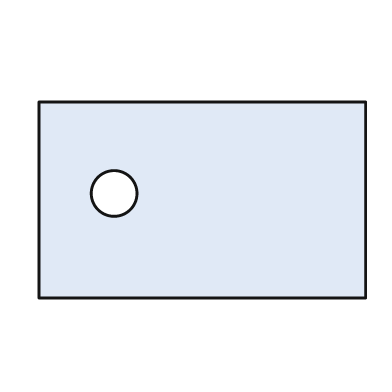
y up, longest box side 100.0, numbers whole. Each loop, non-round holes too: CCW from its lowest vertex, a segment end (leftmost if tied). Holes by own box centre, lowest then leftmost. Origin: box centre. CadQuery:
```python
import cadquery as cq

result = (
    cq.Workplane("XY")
    .moveTo(-50.0, -30.0)
    .lineTo(50.0, -30.0)
    .lineTo(50.0, 30.0)
    .lineTo(-50.0, 30.0)
    .close()
    .moveTo(-27.0, 2.0)
    .circle(7.0)
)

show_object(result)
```